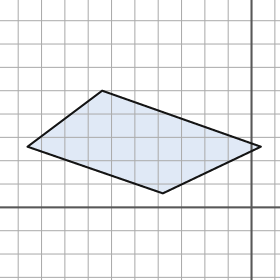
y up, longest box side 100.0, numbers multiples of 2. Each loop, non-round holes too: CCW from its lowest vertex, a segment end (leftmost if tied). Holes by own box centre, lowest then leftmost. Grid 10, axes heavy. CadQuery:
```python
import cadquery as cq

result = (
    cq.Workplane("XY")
    .moveTo(-38.0, 6.0)
    .lineTo(4.0, 26.0)
    .lineTo(-64.0, 50.0)
    .lineTo(-96.0, 26.0)
    .close()
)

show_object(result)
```